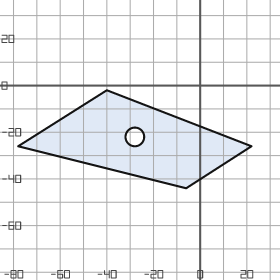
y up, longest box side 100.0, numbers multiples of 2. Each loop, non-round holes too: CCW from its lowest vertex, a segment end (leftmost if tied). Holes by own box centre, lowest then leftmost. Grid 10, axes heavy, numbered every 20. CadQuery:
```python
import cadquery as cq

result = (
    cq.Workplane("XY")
    .moveTo(-6.0, -44.0)
    .lineTo(22.0, -26.0)
    .lineTo(-40.0, -2.0)
    .lineTo(-78.0, -26.0)
    .close()
    .moveTo(-28.0, -22.0)
    .circle(4.0)
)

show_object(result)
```